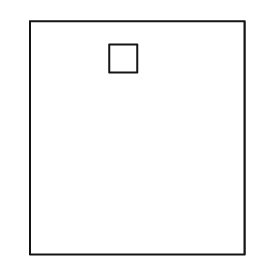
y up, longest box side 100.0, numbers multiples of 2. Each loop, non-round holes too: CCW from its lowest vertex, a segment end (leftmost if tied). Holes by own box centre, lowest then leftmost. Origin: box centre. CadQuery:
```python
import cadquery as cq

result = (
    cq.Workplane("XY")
    .moveTo(-46.0, -50.0)
    .lineTo(46.0, -50.0)
    .lineTo(46.0, 50.0)
    .lineTo(-46.0, 50.0)
    .close()
    .moveTo(-12.0, 28.0)
    .lineTo(0.0, 28.0)
    .lineTo(0.0, 40.0)
    .lineTo(-12.0, 40.0)
    .close()
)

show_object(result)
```